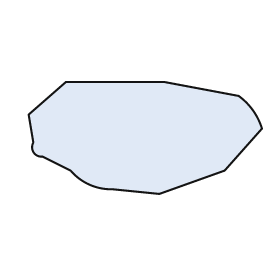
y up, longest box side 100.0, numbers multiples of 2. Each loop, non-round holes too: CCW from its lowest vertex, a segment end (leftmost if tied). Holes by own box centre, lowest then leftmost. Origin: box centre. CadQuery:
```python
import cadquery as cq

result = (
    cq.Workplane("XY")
    .moveTo(6.0, -24.0)
    .lineTo(34.0, -14.0)
    .lineTo(50.0, 4.0)
    .threePointArc((46.0, 12.0), (40.0, 18.0))
    .lineTo(8.0, 24.0)
    .lineTo(-34.0, 24.0)
    .lineTo(-50.0, 10.0)
    .lineTo(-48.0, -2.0)
    .threePointArc((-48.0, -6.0), (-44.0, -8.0))
    .lineTo(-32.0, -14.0)
    .threePointArc((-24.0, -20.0), (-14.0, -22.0))
    .close()
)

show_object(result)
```